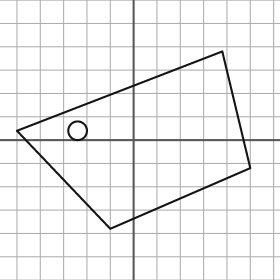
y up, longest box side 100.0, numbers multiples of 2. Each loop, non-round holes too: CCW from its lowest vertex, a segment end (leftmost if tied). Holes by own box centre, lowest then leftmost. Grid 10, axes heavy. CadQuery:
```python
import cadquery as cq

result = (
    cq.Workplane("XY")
    .moveTo(-10.0, -38.0)
    .lineTo(50.0, -12.0)
    .lineTo(38.0, 38.0)
    .lineTo(-50.0, 4.0)
    .close()
    .moveTo(-24.0, 4.0)
    .circle(4.0)
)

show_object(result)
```